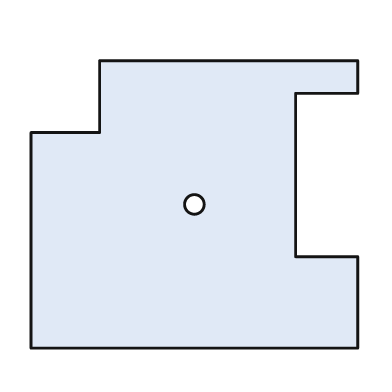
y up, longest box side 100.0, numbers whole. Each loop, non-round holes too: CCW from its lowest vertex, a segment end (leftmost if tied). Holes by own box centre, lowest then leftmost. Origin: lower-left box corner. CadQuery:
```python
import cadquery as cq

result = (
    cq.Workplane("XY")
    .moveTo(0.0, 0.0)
    .lineTo(100.0, 0.0)
    .lineTo(100.0, 28.0)
    .lineTo(81.0, 28.0)
    .lineTo(81.0, 78.0)
    .lineTo(100.0, 78.0)
    .lineTo(100.0, 88.0)
    .lineTo(21.0, 88.0)
    .lineTo(21.0, 66.0)
    .lineTo(0.0, 66.0)
    .close()
    .moveTo(50.0, 44.0)
    .circle(3.0)
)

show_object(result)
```